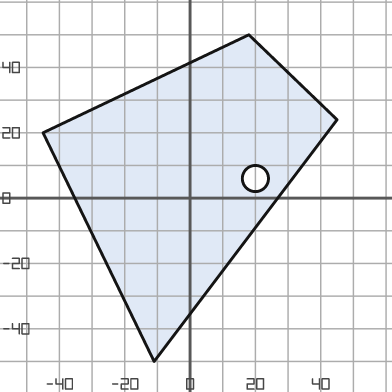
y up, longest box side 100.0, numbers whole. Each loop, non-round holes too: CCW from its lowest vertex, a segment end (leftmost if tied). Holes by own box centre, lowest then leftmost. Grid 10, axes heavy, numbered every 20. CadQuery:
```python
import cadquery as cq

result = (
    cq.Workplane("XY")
    .moveTo(-11.0, -50.0)
    .lineTo(45.0, 24.0)
    .lineTo(18.0, 50.0)
    .lineTo(-45.0, 20.0)
    .close()
    .moveTo(20.0, 6.0)
    .circle(4.0)
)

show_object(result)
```